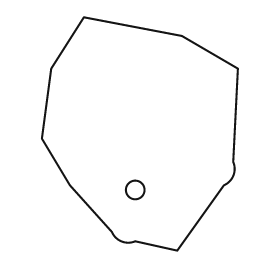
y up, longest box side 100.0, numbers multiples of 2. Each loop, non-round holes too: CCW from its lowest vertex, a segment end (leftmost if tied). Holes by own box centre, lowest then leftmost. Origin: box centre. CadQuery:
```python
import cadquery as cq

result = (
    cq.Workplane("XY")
    .moveTo(16.0, -50.0)
    .lineTo(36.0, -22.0)
    .threePointArc((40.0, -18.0), (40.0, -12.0))
    .lineTo(42.0, 28.0)
    .lineTo(18.0, 42.0)
    .lineTo(-24.0, 50.0)
    .lineTo(-38.0, 28.0)
    .lineTo(-42.0, -2.0)
    .lineTo(-30.0, -22.0)
    .lineTo(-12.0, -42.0)
    .threePointArc((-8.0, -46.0), (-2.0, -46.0))
    .close()
    .moveTo(-2.0, -24.0)
    .circle(4.0)
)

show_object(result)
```